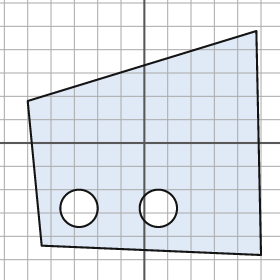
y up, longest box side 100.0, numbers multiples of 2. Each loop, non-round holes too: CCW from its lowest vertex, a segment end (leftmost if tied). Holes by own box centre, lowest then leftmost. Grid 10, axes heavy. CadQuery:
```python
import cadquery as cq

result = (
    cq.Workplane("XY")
    .moveTo(50.0, -48.0)
    .lineTo(48.0, 48.0)
    .lineTo(-50.0, 18.0)
    .lineTo(-44.0, -44.0)
    .close()
    .moveTo(-28.0, -28.0)
    .circle(8.0)
    .moveTo(6.0, -28.0)
    .circle(8.0)
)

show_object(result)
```